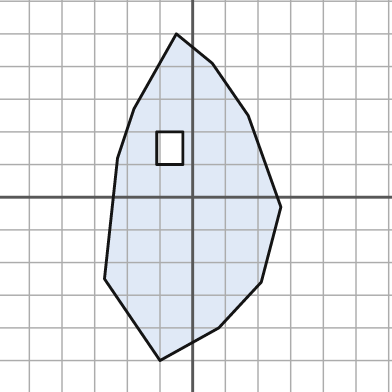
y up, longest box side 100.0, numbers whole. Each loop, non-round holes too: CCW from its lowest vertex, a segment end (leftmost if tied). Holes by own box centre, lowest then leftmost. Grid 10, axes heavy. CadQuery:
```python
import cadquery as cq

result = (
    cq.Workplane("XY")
    .moveTo(-10.0, -50.0)
    .lineTo(8.0, -40.0)
    .lineTo(21.0, -26.0)
    .lineTo(27.0, -3.0)
    .lineTo(17.0, 25.0)
    .lineTo(6.0, 41.0)
    .lineTo(-5.0, 50.0)
    .lineTo(-18.0, 27.0)
    .lineTo(-23.0, 12.0)
    .lineTo(-27.0, -25.0)
    .close()
    .moveTo(-11.0, 10.0)
    .lineTo(-3.0, 10.0)
    .lineTo(-3.0, 20.0)
    .lineTo(-11.0, 20.0)
    .close()
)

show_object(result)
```